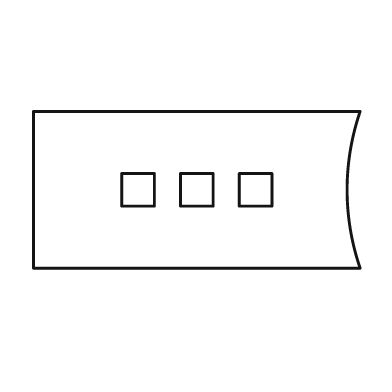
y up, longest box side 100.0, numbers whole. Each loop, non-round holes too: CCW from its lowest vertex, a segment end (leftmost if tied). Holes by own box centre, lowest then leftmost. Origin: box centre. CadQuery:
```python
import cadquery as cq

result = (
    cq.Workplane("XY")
    .moveTo(-50.0, -24.0)
    .lineTo(50.0, -24.0)
    .threePointArc((46.0, 0.0), (50.0, 24.0))
    .lineTo(-50.0, 24.0)
    .close()
    .moveTo(-23.0, -5.0)
    .lineTo(-13.0, -5.0)
    .lineTo(-13.0, 5.0)
    .lineTo(-23.0, 5.0)
    .close()
    .moveTo(-5.0, -5.0)
    .lineTo(5.0, -5.0)
    .lineTo(5.0, 5.0)
    .lineTo(-5.0, 5.0)
    .close()
    .moveTo(13.0, -5.0)
    .lineTo(23.0, -5.0)
    .lineTo(23.0, 5.0)
    .lineTo(13.0, 5.0)
    .close()
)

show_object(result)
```